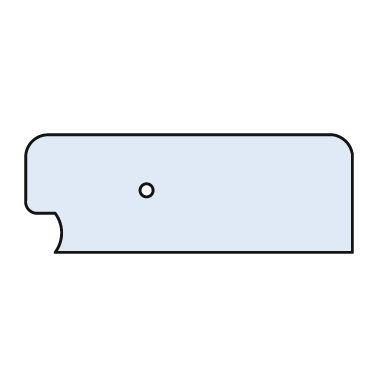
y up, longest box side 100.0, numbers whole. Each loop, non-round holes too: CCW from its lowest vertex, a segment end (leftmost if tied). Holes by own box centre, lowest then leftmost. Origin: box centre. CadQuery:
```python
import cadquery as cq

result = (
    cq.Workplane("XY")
    .moveTo(-41.0, -18.0)
    .lineTo(50.0, -18.0)
    .lineTo(50.0, 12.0)
    .threePointArc((48.0, 16.0), (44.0, 18.0))
    .lineTo(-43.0, 18.0)
    .threePointArc((-48.0, 16.0), (-50.0, 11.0))
    .lineTo(-50.0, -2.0)
    .threePointArc((-49.0, -5.0), (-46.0, -6.0))
    .lineTo(-41.0, -6.0)
    .threePointArc((-39.0, -12.0), (-41.0, -18.0))
    .close()
    .moveTo(-13.0, 1.0)
    .circle(2.0)
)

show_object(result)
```